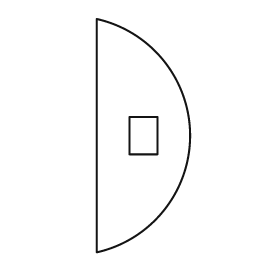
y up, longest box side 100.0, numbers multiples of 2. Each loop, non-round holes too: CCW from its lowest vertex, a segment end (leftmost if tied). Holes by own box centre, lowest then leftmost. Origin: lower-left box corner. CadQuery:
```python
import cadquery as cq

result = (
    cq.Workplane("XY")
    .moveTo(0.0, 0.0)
    .threePointArc((40.0, 50.0), (0.0, 100.0))
    .close()
    .moveTo(14.0, 42.0)
    .lineTo(26.0, 42.0)
    .lineTo(26.0, 58.0)
    .lineTo(14.0, 58.0)
    .close()
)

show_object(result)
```